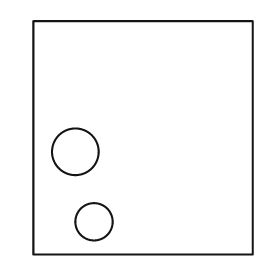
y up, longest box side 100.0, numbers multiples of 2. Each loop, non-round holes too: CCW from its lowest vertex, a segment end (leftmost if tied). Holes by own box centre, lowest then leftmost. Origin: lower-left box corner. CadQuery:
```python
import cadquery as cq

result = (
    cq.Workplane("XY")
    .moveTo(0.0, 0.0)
    .lineTo(94.0, 0.0)
    .lineTo(94.0, 100.0)
    .lineTo(0.0, 100.0)
    .close()
    .moveTo(26.0, 14.0)
    .circle(8.0)
    .moveTo(18.0, 44.0)
    .circle(10.0)
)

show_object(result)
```